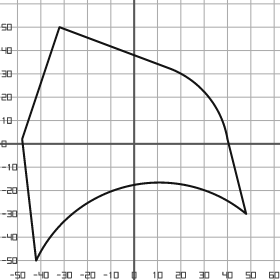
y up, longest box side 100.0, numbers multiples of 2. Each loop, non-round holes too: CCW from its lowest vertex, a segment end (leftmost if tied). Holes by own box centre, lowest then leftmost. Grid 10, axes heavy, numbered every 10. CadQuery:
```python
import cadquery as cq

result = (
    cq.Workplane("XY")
    .moveTo(-42.0, -50.0)
    .threePointArc((-2.0, -18.0), (48.0, -30.0))
    .lineTo(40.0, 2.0)
    .threePointArc((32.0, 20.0), (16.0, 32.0))
    .lineTo(-32.0, 50.0)
    .lineTo(-48.0, 2.0)
    .close()
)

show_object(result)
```